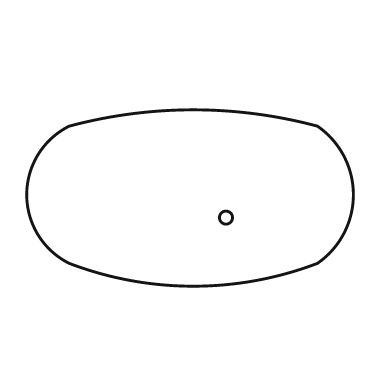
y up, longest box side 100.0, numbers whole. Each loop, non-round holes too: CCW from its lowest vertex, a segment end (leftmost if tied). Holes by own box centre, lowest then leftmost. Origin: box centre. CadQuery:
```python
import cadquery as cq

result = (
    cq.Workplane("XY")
    .moveTo(-37.0, -20.0)
    .threePointArc((1.0, -27.0), (39.0, -20.0))
    .threePointArc((50.0, 1.0), (39.0, 22.0))
    .threePointArc((1.0, 27.0), (-37.0, 22.0))
    .threePointArc((-50.0, 1.0), (-37.0, -20.0))
    .close()
    .moveTo(11.0, -6.0)
    .circle(2.0)
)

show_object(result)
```